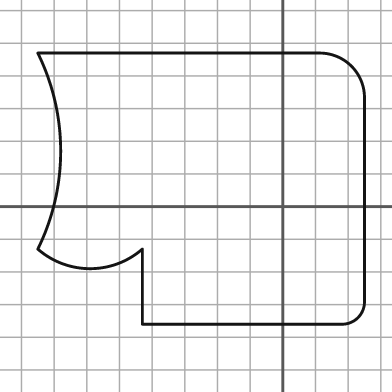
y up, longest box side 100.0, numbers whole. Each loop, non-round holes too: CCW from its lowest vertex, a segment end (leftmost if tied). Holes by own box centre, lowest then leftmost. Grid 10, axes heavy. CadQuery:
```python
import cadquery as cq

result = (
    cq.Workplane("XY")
    .moveTo(-43.0, -36.0)
    .lineTo(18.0, -36.0)
    .threePointArc((23.0, -34.0), (25.0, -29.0))
    .lineTo(25.0, 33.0)
    .threePointArc((21.0, 43.0), (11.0, 47.0))
    .lineTo(-75.0, 47.0)
    .threePointArc((-68.0, 17.0), (-75.0, -13.0))
    .threePointArc((-59.0, -19.0), (-43.0, -13.0))
    .close()
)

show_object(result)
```